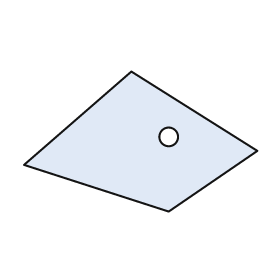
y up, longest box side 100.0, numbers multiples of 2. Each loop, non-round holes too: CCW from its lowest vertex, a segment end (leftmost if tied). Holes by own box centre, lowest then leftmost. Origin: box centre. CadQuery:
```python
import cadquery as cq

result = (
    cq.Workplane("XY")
    .moveTo(12.0, -30.0)
    .lineTo(50.0, -4.0)
    .lineTo(-4.0, 30.0)
    .lineTo(-50.0, -10.0)
    .close()
    .moveTo(12.0, 2.0)
    .circle(4.0)
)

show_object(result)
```